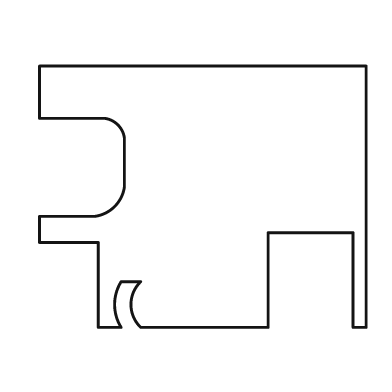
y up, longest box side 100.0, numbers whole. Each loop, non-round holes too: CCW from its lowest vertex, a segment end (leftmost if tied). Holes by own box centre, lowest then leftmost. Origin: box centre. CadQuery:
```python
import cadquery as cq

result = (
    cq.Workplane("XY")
    .moveTo(-32.0, -40.0)
    .lineTo(-25.0, -40.0)
    .threePointArc((-27.0, -33.0), (-25.0, -26.0))
    .lineTo(-19.0, -26.0)
    .threePointArc((-22.0, -33.0), (-19.0, -40.0))
    .lineTo(20.0, -40.0)
    .lineTo(20.0, -11.0)
    .lineTo(46.0, -11.0)
    .lineTo(46.0, -40.0)
    .lineTo(50.0, -40.0)
    .lineTo(50.0, 40.0)
    .lineTo(-50.0, 40.0)
    .lineTo(-50.0, 24.0)
    .lineTo(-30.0, 24.0)
    .threePointArc((-26.0, 22.0), (-24.0, 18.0))
    .lineTo(-24.0, 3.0)
    .threePointArc((-27.0, -3.0), (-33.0, -6.0))
    .lineTo(-50.0, -6.0)
    .lineTo(-50.0, -14.0)
    .lineTo(-32.0, -14.0)
    .close()
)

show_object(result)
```